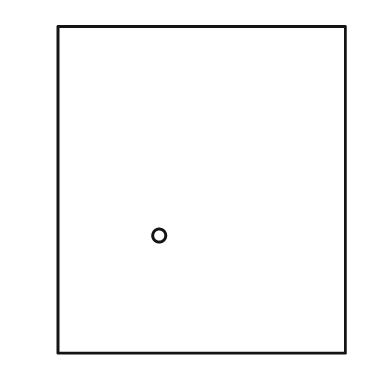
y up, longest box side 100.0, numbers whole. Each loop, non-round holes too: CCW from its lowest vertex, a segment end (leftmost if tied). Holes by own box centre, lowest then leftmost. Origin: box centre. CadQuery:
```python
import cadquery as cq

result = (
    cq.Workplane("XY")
    .moveTo(-44.0, -50.0)
    .lineTo(44.0, -50.0)
    .lineTo(44.0, 50.0)
    .lineTo(-44.0, 50.0)
    .close()
    .moveTo(-13.0, -14.0)
    .circle(2.0)
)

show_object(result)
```